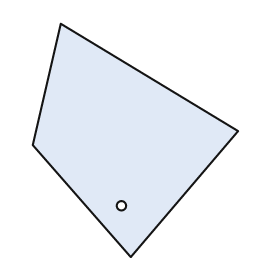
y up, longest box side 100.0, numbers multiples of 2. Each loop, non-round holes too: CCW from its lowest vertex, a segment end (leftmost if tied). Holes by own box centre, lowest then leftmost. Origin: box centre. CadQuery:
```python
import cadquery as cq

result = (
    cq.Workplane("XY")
    .moveTo(-2.0, -50.0)
    .lineTo(44.0, 4.0)
    .lineTo(-32.0, 50.0)
    .lineTo(-44.0, -2.0)
    .close()
    .moveTo(-6.0, -28.0)
    .circle(2.0)
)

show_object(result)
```